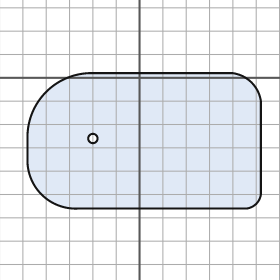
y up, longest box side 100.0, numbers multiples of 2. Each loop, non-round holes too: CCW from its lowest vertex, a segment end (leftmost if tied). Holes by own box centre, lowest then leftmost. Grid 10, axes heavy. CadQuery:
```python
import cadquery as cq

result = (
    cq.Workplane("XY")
    .moveTo(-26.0, -56.0)
    .lineTo(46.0, -56.0)
    .threePointArc((50.0, -54.0), (52.0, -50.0))
    .lineTo(52.0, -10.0)
    .threePointArc((48.0, -2.0), (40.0, 2.0))
    .lineTo(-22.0, 2.0)
    .threePointArc((-40.0, -6.0), (-48.0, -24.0))
    .lineTo(-48.0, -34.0)
    .threePointArc((-42.0, -50.0), (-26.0, -56.0))
    .close()
    .moveTo(-20.0, -26.0)
    .circle(2.0)
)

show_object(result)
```